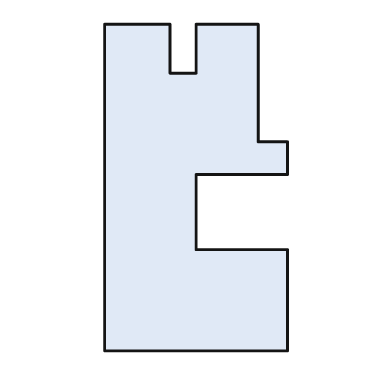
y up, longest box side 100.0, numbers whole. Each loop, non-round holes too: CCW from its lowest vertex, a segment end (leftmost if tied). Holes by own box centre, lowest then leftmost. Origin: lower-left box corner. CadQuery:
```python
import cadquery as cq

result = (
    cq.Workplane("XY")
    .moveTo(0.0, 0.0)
    .lineTo(56.0, 0.0)
    .lineTo(56.0, 31.0)
    .lineTo(28.0, 31.0)
    .lineTo(28.0, 54.0)
    .lineTo(56.0, 54.0)
    .lineTo(56.0, 64.0)
    .lineTo(47.0, 64.0)
    .lineTo(47.0, 100.0)
    .lineTo(28.0, 100.0)
    .lineTo(28.0, 85.0)
    .lineTo(20.0, 85.0)
    .lineTo(20.0, 100.0)
    .lineTo(0.0, 100.0)
    .close()
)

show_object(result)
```